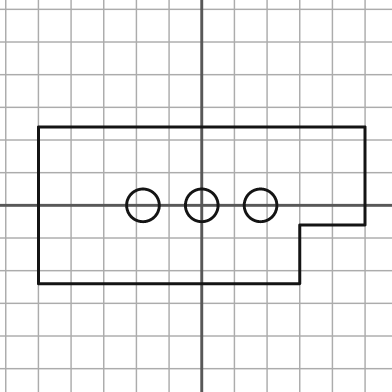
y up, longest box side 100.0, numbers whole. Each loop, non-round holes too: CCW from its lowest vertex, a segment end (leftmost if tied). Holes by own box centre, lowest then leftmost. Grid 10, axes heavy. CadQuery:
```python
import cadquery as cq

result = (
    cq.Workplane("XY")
    .moveTo(-50.0, -24.0)
    .lineTo(30.0, -24.0)
    .lineTo(30.0, -6.0)
    .lineTo(50.0, -6.0)
    .lineTo(50.0, 24.0)
    .lineTo(-50.0, 24.0)
    .close()
    .moveTo(-18.0, 0.0)
    .circle(5.0)
    .moveTo(0.0, 0.0)
    .circle(5.0)
    .moveTo(18.0, 0.0)
    .circle(5.0)
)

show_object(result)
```